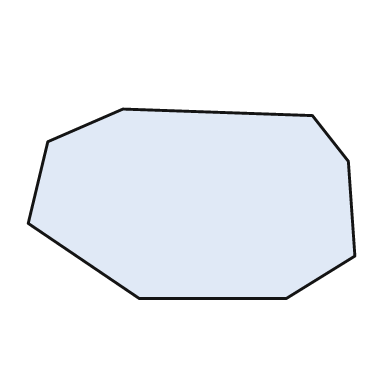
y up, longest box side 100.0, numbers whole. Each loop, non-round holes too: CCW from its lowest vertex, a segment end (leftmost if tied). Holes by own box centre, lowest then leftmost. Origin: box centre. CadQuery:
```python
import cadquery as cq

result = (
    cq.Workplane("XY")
    .moveTo(-16.0, -29.0)
    .lineTo(29.0, -29.0)
    .lineTo(50.0, -16.0)
    .lineTo(48.0, 13.0)
    .lineTo(37.0, 27.0)
    .lineTo(-21.0, 29.0)
    .lineTo(-44.0, 19.0)
    .lineTo(-50.0, -6.0)
    .close()
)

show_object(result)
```